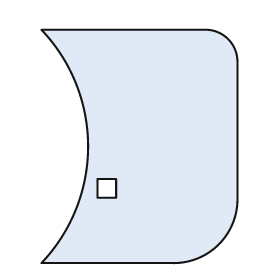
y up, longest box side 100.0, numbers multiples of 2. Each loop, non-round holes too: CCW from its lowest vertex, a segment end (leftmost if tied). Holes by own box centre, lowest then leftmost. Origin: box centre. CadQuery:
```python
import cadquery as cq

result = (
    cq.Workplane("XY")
    .moveTo(-42.0, -50.0)
    .lineTo(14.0, -50.0)
    .threePointArc((34.0, -42.0), (42.0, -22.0))
    .lineTo(42.0, 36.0)
    .threePointArc((38.0, 46.0), (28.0, 50.0))
    .lineTo(-42.0, 50.0)
    .threePointArc((-22.0, 0.0), (-42.0, -50.0))
    .close()
    .moveTo(-18.0, -22.0)
    .lineTo(-10.0, -22.0)
    .lineTo(-10.0, -14.0)
    .lineTo(-18.0, -14.0)
    .close()
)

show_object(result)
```